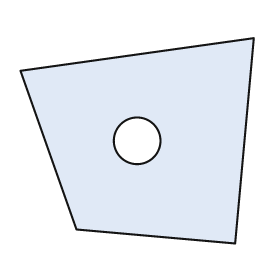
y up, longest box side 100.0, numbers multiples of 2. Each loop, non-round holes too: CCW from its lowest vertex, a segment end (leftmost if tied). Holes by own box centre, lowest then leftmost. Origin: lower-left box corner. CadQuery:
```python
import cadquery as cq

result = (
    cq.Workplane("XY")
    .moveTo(92.0, 0.0)
    .lineTo(100.0, 88.0)
    .lineTo(0.0, 74.0)
    .lineTo(24.0, 6.0)
    .close()
    .moveTo(50.0, 44.0)
    .circle(10.0)
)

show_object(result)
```